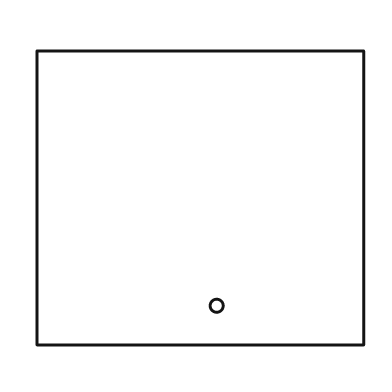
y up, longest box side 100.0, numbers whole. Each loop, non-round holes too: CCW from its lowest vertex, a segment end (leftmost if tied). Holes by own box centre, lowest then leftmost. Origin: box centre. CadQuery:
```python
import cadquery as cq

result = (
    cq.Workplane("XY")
    .moveTo(-50.0, -45.0)
    .lineTo(50.0, -45.0)
    .lineTo(50.0, 45.0)
    .lineTo(-50.0, 45.0)
    .close()
    .moveTo(5.0, -33.0)
    .circle(2.0)
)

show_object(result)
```